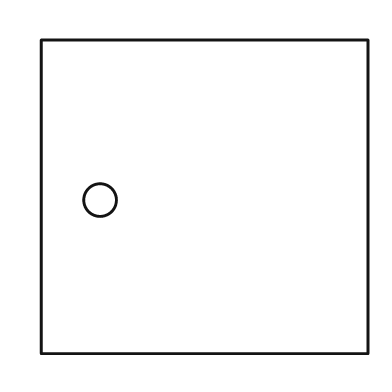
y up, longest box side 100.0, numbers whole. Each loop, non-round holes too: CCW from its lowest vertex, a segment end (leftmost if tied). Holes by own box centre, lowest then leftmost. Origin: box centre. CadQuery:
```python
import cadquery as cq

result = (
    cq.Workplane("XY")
    .moveTo(-50.0, -48.0)
    .lineTo(50.0, -48.0)
    .lineTo(50.0, 48.0)
    .lineTo(-50.0, 48.0)
    .close()
    .moveTo(-32.0, -1.0)
    .circle(5.0)
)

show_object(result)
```